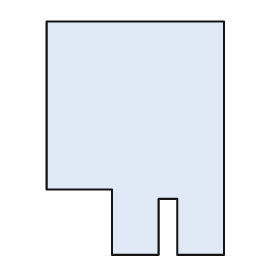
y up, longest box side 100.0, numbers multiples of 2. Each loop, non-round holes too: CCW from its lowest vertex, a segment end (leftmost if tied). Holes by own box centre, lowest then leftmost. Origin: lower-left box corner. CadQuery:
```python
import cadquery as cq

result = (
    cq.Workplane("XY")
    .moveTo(28.0, 0.0)
    .lineTo(48.0, 0.0)
    .lineTo(48.0, 24.0)
    .lineTo(56.0, 24.0)
    .lineTo(56.0, 0.0)
    .lineTo(76.0, 0.0)
    .lineTo(76.0, 100.0)
    .lineTo(0.0, 100.0)
    .lineTo(0.0, 28.0)
    .lineTo(28.0, 28.0)
    .close()
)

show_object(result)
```